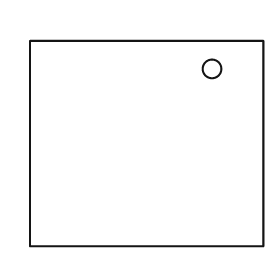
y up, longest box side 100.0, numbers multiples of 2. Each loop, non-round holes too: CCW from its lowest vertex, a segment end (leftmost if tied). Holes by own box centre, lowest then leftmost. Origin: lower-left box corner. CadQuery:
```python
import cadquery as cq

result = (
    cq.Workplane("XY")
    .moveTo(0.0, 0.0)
    .lineTo(100.0, 0.0)
    .lineTo(100.0, 88.0)
    .lineTo(0.0, 88.0)
    .close()
    .moveTo(78.0, 76.0)
    .circle(4.0)
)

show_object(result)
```